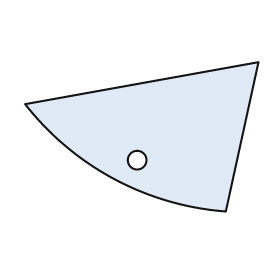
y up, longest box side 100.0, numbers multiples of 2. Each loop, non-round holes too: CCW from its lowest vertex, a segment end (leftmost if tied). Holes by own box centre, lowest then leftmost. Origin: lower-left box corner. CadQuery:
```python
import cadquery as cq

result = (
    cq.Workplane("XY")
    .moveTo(86.0, 0.0)
    .lineTo(100.0, 64.0)
    .lineTo(0.0, 46.0)
    .threePointArc((38.0, 14.0), (86.0, 0.0))
    .close()
    .moveTo(48.0, 22.0)
    .circle(4.0)
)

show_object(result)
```